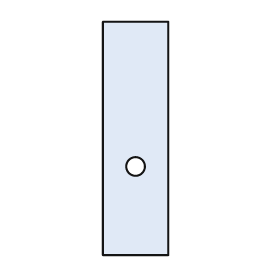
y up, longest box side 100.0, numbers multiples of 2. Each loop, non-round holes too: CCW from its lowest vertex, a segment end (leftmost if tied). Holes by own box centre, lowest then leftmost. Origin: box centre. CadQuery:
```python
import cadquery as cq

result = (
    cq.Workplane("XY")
    .moveTo(-14.0, -50.0)
    .lineTo(14.0, -50.0)
    .lineTo(14.0, 50.0)
    .lineTo(-14.0, 50.0)
    .close()
    .moveTo(0.0, -12.0)
    .circle(4.0)
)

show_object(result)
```